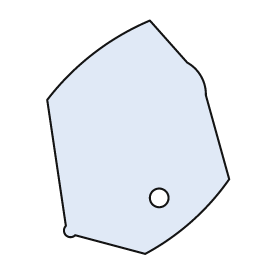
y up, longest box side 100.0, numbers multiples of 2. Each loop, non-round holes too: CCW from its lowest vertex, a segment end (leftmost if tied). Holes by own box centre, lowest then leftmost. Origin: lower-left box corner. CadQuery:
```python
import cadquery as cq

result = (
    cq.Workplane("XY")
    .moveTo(42.0, 0.0)
    .threePointArc((62.0, 14.0), (78.0, 32.0))
    .lineTo(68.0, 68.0)
    .threePointArc((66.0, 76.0), (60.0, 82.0))
    .lineTo(44.0, 100.0)
    .threePointArc((20.0, 86.0), (0.0, 66.0))
    .lineTo(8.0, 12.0)
    .threePointArc((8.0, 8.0), (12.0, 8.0))
    .close()
    .moveTo(48.0, 24.0)
    .circle(4.0)
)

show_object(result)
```